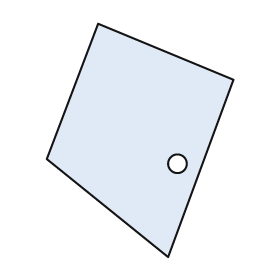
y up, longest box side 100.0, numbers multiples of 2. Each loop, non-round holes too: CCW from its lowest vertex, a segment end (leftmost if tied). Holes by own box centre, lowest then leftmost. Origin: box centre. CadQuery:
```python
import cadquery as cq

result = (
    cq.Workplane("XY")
    .moveTo(12.0, -50.0)
    .lineTo(40.0, 26.0)
    .lineTo(-18.0, 50.0)
    .lineTo(-40.0, -8.0)
    .close()
    .moveTo(16.0, -10.0)
    .circle(4.0)
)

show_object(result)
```